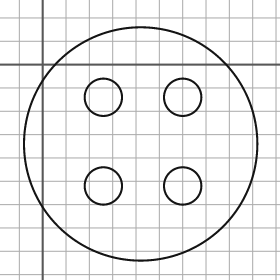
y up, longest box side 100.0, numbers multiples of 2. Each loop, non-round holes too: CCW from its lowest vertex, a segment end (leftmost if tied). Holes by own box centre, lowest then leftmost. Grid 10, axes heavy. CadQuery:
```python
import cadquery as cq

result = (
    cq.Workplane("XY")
    .moveTo(42.0, -34.0)
    .circle(50.0)
    .moveTo(26.0, -52.0)
    .circle(8.0)
    .moveTo(60.0, -52.0)
    .circle(8.0)
    .moveTo(26.0, -14.0)
    .circle(8.0)
    .moveTo(60.0, -14.0)
    .circle(8.0)
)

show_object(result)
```